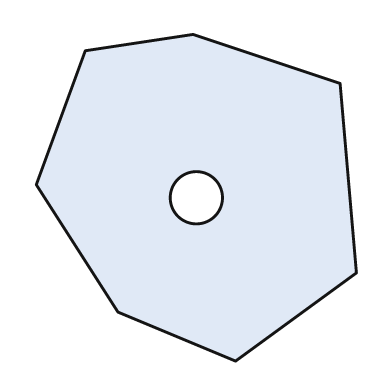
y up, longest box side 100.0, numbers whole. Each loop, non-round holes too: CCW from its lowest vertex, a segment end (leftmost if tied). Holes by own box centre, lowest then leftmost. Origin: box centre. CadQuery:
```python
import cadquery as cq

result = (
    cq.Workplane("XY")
    .moveTo(12.0, -50.0)
    .lineTo(49.0, -23.0)
    .lineTo(44.0, 35.0)
    .lineTo(-1.0, 50.0)
    .lineTo(-34.0, 45.0)
    .lineTo(-49.0, 4.0)
    .lineTo(-24.0, -35.0)
    .close()
    .moveTo(0.0, 0.0)
    .circle(8.0)
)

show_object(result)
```